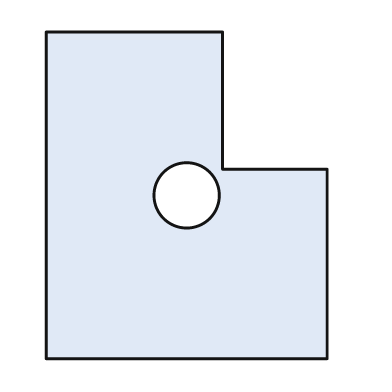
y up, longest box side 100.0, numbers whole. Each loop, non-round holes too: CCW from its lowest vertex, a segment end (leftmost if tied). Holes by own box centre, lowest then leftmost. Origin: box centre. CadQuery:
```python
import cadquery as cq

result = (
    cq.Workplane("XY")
    .moveTo(-43.0, -50.0)
    .lineTo(43.0, -50.0)
    .lineTo(43.0, 8.0)
    .lineTo(11.0, 8.0)
    .lineTo(11.0, 50.0)
    .lineTo(-43.0, 50.0)
    .close()
    .moveTo(0.0, 0.0)
    .circle(10.0)
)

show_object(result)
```